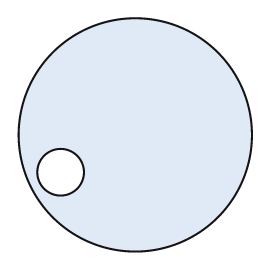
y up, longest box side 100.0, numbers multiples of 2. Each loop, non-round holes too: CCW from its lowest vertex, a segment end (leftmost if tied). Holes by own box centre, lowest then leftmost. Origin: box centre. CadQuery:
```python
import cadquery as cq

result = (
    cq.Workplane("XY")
    .moveTo(0.0, 0.0)
    .circle(50.0)
    .moveTo(-32.0, -16.0)
    .circle(10.0)
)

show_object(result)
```